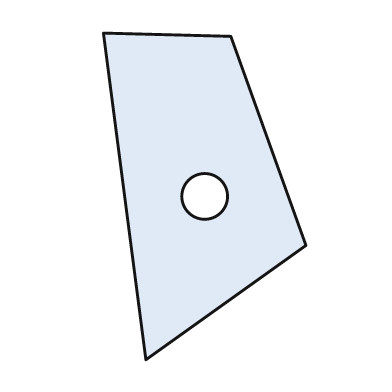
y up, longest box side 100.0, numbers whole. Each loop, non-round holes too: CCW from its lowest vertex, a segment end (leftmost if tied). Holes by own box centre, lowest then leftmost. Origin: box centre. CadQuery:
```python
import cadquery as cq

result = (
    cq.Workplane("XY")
    .moveTo(-18.0, -50.0)
    .lineTo(31.0, -15.0)
    .lineTo(8.0, 49.0)
    .lineTo(-31.0, 50.0)
    .close()
    .moveTo(0.0, 0.0)
    .circle(7.0)
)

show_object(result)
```